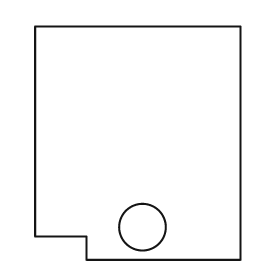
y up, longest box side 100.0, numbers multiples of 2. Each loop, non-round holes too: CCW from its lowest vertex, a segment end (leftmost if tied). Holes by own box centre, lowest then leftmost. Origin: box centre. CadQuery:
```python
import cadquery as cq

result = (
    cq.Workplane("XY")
    .moveTo(-22.0, -50.0)
    .lineTo(44.0, -50.0)
    .lineTo(44.0, 50.0)
    .lineTo(-44.0, 50.0)
    .lineTo(-44.0, -40.0)
    .lineTo(-22.0, -40.0)
    .close()
    .moveTo(2.0, -36.0)
    .circle(10.0)
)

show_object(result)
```